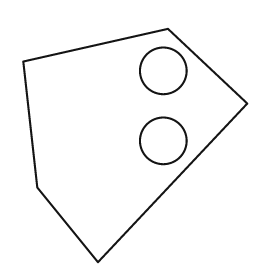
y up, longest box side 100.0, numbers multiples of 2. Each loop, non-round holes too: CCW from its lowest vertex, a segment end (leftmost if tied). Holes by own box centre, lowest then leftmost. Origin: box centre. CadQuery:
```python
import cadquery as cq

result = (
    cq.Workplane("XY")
    .moveTo(-16.0, -50.0)
    .lineTo(48.0, 18.0)
    .lineTo(14.0, 50.0)
    .lineTo(-48.0, 36.0)
    .lineTo(-42.0, -18.0)
    .close()
    .moveTo(12.0, 2.0)
    .circle(10.0)
    .moveTo(12.0, 32.0)
    .circle(10.0)
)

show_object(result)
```